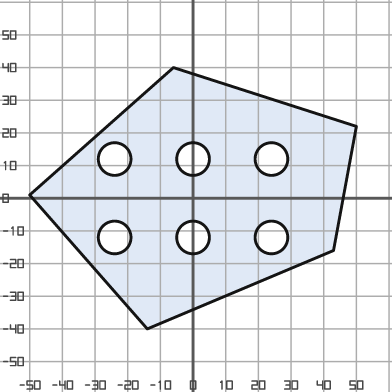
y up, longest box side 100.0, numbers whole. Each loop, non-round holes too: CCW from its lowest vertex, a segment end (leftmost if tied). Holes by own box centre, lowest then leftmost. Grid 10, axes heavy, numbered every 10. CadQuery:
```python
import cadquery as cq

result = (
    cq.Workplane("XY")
    .moveTo(-14.0, -40.0)
    .lineTo(43.0, -16.0)
    .lineTo(50.0, 22.0)
    .lineTo(-6.0, 40.0)
    .lineTo(-50.0, 1.0)
    .close()
    .moveTo(-24.0, -12.0)
    .circle(5.0)
    .moveTo(0.0, -12.0)
    .circle(5.0)
    .moveTo(24.0, -12.0)
    .circle(5.0)
    .moveTo(-24.0, 12.0)
    .circle(5.0)
    .moveTo(0.0, 12.0)
    .circle(5.0)
    .moveTo(24.0, 12.0)
    .circle(5.0)
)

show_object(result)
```